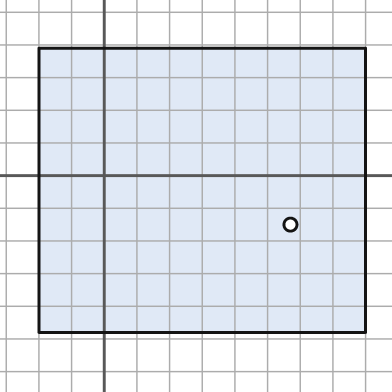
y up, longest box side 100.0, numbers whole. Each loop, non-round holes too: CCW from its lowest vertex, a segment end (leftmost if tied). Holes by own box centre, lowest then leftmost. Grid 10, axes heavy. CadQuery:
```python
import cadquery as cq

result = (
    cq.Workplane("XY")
    .moveTo(-20.0, -48.0)
    .lineTo(80.0, -48.0)
    .lineTo(80.0, 39.0)
    .lineTo(-20.0, 39.0)
    .close()
    .moveTo(57.0, -15.0)
    .circle(2.0)
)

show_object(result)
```